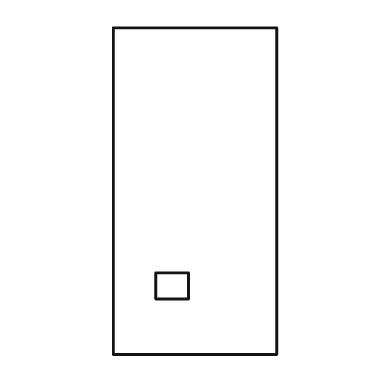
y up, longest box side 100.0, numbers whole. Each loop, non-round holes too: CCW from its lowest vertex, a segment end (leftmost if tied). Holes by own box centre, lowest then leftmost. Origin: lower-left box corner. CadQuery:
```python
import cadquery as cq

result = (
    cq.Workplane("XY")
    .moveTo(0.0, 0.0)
    .lineTo(50.0, 0.0)
    .lineTo(50.0, 100.0)
    .lineTo(0.0, 100.0)
    .close()
    .moveTo(13.0, 17.0)
    .lineTo(23.0, 17.0)
    .lineTo(23.0, 25.0)
    .lineTo(13.0, 25.0)
    .close()
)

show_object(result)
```